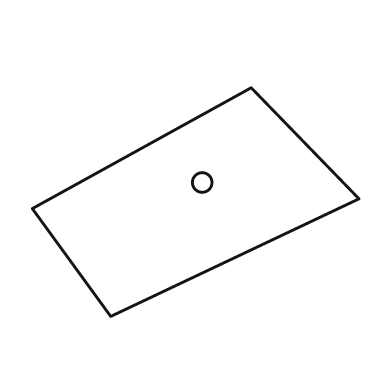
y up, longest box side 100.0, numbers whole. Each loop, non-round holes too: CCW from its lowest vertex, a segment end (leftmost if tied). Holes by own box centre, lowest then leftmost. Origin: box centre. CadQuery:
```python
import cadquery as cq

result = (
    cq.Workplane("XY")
    .moveTo(-26.0, -35.0)
    .lineTo(50.0, 1.0)
    .lineTo(17.0, 35.0)
    .lineTo(-50.0, -2.0)
    .close()
    .moveTo(2.0, 6.0)
    .circle(3.0)
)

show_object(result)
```